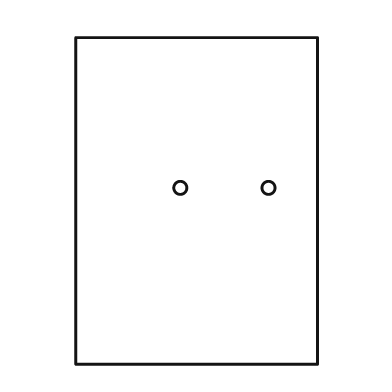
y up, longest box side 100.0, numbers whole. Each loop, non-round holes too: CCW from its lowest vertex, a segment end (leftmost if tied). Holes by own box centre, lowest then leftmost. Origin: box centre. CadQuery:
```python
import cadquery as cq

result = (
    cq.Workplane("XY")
    .moveTo(-37.0, -50.0)
    .lineTo(37.0, -50.0)
    .lineTo(37.0, 50.0)
    .lineTo(-37.0, 50.0)
    .close()
    .moveTo(-5.0, 4.0)
    .circle(2.0)
    .moveTo(22.0, 4.0)
    .circle(2.0)
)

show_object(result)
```